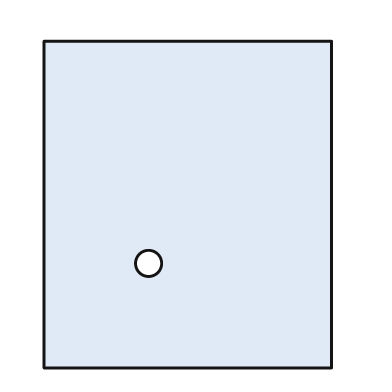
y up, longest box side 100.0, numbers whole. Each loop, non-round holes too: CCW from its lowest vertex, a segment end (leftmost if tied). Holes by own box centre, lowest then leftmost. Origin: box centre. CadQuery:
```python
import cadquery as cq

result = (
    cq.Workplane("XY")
    .moveTo(-44.0, -50.0)
    .lineTo(44.0, -50.0)
    .lineTo(44.0, 50.0)
    .lineTo(-44.0, 50.0)
    .close()
    .moveTo(-12.0, -18.0)
    .circle(4.0)
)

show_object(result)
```